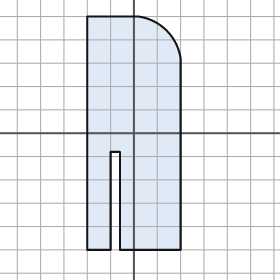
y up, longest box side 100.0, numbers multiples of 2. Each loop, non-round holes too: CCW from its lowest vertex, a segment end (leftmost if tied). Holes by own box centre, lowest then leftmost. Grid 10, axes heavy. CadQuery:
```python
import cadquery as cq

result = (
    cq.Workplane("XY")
    .moveTo(-20.0, -50.0)
    .lineTo(-10.0, -50.0)
    .lineTo(-10.0, -8.0)
    .lineTo(-6.0, -8.0)
    .lineTo(-6.0, -50.0)
    .lineTo(20.0, -50.0)
    .lineTo(20.0, 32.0)
    .threePointArc((14.0, 44.0), (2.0, 50.0))
    .lineTo(-20.0, 50.0)
    .close()
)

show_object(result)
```